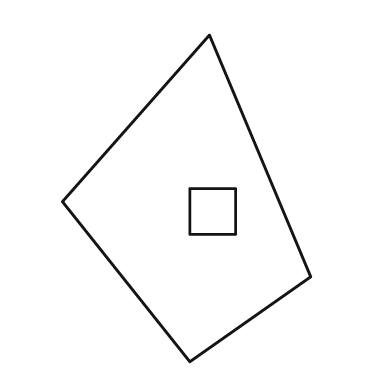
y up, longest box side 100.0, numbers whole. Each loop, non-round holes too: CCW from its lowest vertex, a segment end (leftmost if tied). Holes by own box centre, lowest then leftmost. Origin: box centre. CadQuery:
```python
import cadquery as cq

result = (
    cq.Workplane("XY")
    .moveTo(1.0, -50.0)
    .lineTo(38.0, -24.0)
    .lineTo(7.0, 50.0)
    .lineTo(-38.0, -1.0)
    .close()
    .moveTo(1.0, -11.0)
    .lineTo(15.0, -11.0)
    .lineTo(15.0, 3.0)
    .lineTo(1.0, 3.0)
    .close()
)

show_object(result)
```